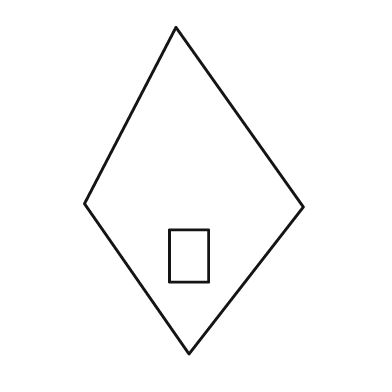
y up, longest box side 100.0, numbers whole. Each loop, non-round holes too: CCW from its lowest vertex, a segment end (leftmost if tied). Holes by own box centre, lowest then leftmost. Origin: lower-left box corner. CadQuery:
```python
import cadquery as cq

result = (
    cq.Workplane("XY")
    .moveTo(32.0, 0.0)
    .lineTo(67.0, 45.0)
    .lineTo(28.0, 100.0)
    .lineTo(0.0, 46.0)
    .close()
    .moveTo(26.0, 22.0)
    .lineTo(38.0, 22.0)
    .lineTo(38.0, 38.0)
    .lineTo(26.0, 38.0)
    .close()
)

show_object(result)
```